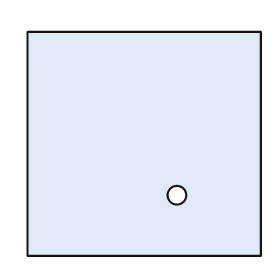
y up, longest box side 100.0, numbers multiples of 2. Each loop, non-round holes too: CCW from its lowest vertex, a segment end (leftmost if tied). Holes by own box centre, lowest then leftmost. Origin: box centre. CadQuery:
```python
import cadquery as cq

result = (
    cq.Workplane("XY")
    .moveTo(-50.0, -48.0)
    .lineTo(50.0, -48.0)
    .lineTo(50.0, 48.0)
    .lineTo(-50.0, 48.0)
    .close()
    .moveTo(14.0, -22.0)
    .circle(4.0)
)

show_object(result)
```